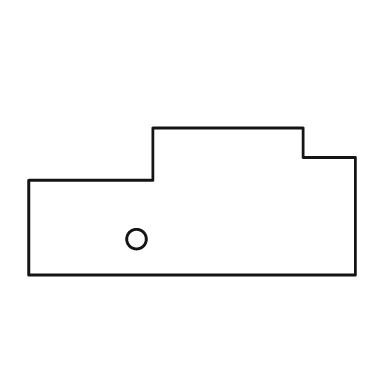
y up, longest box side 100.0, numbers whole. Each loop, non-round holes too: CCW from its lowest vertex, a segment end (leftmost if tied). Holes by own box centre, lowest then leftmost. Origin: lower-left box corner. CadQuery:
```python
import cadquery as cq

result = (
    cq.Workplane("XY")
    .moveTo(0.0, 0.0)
    .lineTo(100.0, 0.0)
    .lineTo(100.0, 36.0)
    .lineTo(84.0, 36.0)
    .lineTo(84.0, 45.0)
    .lineTo(38.0, 45.0)
    .lineTo(38.0, 29.0)
    .lineTo(0.0, 29.0)
    .close()
    .moveTo(33.0, 11.0)
    .circle(3.0)
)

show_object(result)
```